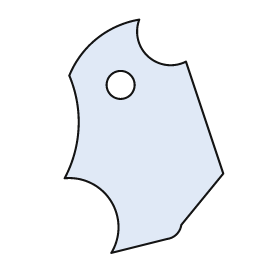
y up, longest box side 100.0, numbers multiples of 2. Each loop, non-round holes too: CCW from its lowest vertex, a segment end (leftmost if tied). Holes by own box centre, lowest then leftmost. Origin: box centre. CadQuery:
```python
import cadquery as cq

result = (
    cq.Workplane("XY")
    .moveTo(-14.0, -50.0)
    .lineTo(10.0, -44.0)
    .threePointArc((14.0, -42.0), (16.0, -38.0))
    .lineTo(34.0, -16.0)
    .lineTo(18.0, 32.0)
    .threePointArc((2.0, 34.0), (-2.0, 50.0))
    .threePointArc((-20.0, 42.0), (-32.0, 26.0))
    .threePointArc((-28.0, 4.0), (-34.0, -18.0))
    .threePointArc((-14.0, -28.0), (-14.0, -50.0))
    .close()
    .moveTo(-10.0, 22.0)
    .circle(6.0)
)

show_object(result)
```